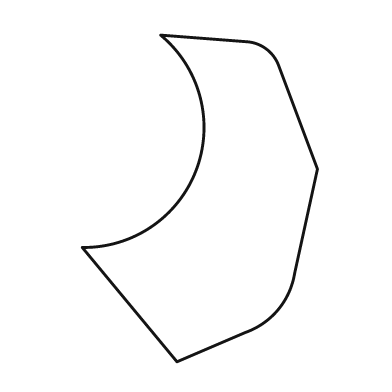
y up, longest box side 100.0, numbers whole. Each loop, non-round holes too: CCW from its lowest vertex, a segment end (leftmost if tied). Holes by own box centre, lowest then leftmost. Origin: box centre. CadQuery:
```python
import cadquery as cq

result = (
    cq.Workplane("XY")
    .moveTo(-7.0, -50.0)
    .lineTo(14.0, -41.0)
    .threePointArc((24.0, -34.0), (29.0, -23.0))
    .lineTo(36.0, 9.0)
    .lineTo(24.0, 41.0)
    .threePointArc((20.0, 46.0), (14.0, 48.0))
    .lineTo(-12.0, 50.0)
    .threePointArc((-1.0, 9.0), (-36.0, -15.0))
    .close()
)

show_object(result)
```